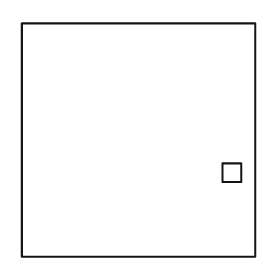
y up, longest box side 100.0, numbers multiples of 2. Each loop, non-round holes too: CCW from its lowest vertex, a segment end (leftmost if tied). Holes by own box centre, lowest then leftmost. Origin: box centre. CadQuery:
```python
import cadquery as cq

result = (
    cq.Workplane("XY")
    .moveTo(-50.0, -50.0)
    .lineTo(50.0, -50.0)
    .lineTo(50.0, 50.0)
    .lineTo(-50.0, 50.0)
    .close()
    .moveTo(36.0, -18.0)
    .lineTo(44.0, -18.0)
    .lineTo(44.0, -10.0)
    .lineTo(36.0, -10.0)
    .close()
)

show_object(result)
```